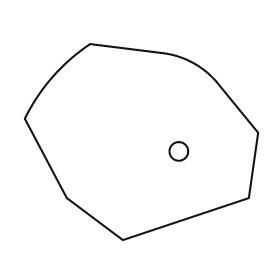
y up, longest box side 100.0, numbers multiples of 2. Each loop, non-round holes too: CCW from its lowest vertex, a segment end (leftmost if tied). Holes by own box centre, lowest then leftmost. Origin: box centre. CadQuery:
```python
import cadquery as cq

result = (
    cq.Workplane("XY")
    .moveTo(-8.0, -42.0)
    .lineTo(46.0, -24.0)
    .lineTo(50.0, 4.0)
    .lineTo(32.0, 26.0)
    .threePointArc((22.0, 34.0), (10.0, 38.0))
    .lineTo(-22.0, 42.0)
    .threePointArc((-38.0, 28.0), (-50.0, 10.0))
    .lineTo(-32.0, -24.0)
    .close()
    .moveTo(16.0, -4.0)
    .circle(4.0)
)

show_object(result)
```